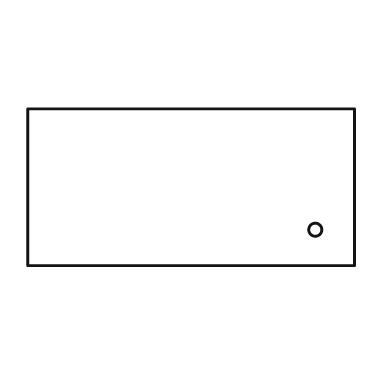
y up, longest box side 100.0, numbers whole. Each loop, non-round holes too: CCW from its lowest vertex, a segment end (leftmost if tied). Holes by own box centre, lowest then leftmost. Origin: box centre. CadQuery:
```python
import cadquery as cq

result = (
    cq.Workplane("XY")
    .moveTo(-50.0, -24.0)
    .lineTo(50.0, -24.0)
    .lineTo(50.0, 24.0)
    .lineTo(-50.0, 24.0)
    .close()
    .moveTo(38.0, -13.0)
    .circle(2.0)
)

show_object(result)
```